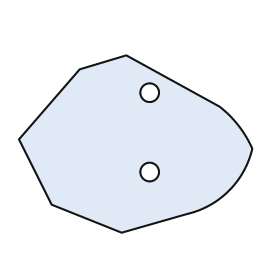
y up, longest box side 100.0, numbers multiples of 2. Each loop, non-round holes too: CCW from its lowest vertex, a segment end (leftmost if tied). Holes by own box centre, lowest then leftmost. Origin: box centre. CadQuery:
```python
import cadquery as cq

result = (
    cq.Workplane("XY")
    .moveTo(-6.0, -38.0)
    .lineTo(22.0, -30.0)
    .threePointArc((40.0, -20.0), (50.0, -2.0))
    .threePointArc((44.0, 8.0), (36.0, 16.0))
    .lineTo(-4.0, 38.0)
    .lineTo(-24.0, 32.0)
    .lineTo(-50.0, 2.0)
    .lineTo(-36.0, -26.0)
    .close()
    .moveTo(6.0, -12.0)
    .circle(4.0)
    .moveTo(6.0, 22.0)
    .circle(4.0)
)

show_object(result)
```